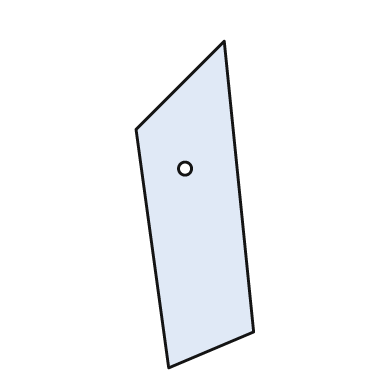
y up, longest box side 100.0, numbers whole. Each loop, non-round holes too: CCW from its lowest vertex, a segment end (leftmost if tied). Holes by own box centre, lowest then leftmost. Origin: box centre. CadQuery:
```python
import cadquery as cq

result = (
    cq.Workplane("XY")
    .moveTo(-8.0, -50.0)
    .lineTo(18.0, -39.0)
    .lineTo(9.0, 50.0)
    .lineTo(-18.0, 23.0)
    .close()
    .moveTo(-3.0, 11.0)
    .circle(2.0)
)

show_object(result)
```